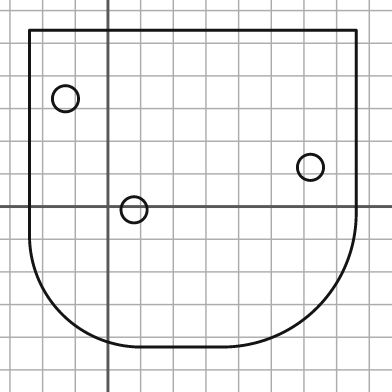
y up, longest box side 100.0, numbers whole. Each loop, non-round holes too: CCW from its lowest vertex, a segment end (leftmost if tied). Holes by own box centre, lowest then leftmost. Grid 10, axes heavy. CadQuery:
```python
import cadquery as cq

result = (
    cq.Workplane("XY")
    .moveTo(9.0, -43.0)
    .lineTo(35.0, -43.0)
    .threePointArc((64.0, -31.0), (76.0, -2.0))
    .lineTo(76.0, 54.0)
    .lineTo(-24.0, 54.0)
    .lineTo(-24.0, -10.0)
    .threePointArc((-14.0, -33.0), (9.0, -43.0))
    .close()
    .moveTo(8.0, -1.0)
    .circle(4.0)
    .moveTo(62.0, 12.0)
    .circle(4.0)
    .moveTo(-13.0, 33.0)
    .circle(4.0)
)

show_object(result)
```